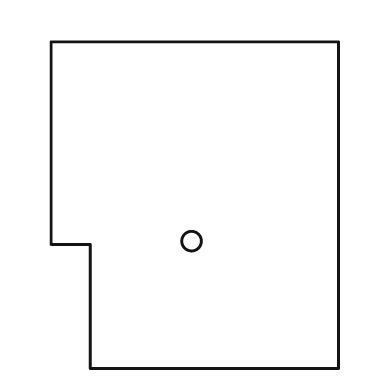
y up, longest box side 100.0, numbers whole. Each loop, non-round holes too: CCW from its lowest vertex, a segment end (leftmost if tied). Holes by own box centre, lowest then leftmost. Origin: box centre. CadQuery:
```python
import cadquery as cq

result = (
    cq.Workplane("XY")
    .moveTo(-32.0, -50.0)
    .lineTo(44.0, -50.0)
    .lineTo(44.0, 50.0)
    .lineTo(-44.0, 50.0)
    .lineTo(-44.0, -12.0)
    .lineTo(-32.0, -12.0)
    .close()
    .moveTo(-1.0, -11.0)
    .circle(3.0)
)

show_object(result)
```